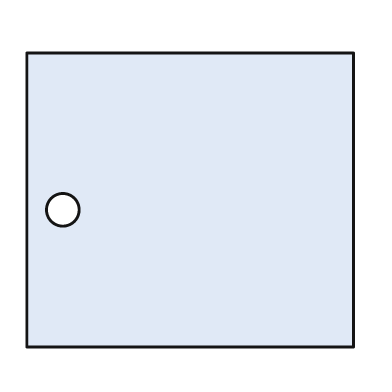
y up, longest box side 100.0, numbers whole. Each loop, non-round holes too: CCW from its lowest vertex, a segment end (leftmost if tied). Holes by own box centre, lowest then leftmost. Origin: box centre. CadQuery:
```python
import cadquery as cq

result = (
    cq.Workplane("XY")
    .moveTo(-50.0, -45.0)
    .lineTo(50.0, -45.0)
    .lineTo(50.0, 45.0)
    .lineTo(-50.0, 45.0)
    .close()
    .moveTo(-39.0, -3.0)
    .circle(5.0)
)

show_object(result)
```